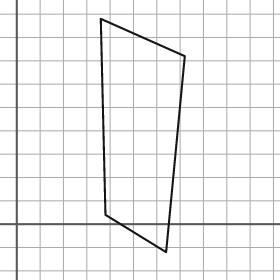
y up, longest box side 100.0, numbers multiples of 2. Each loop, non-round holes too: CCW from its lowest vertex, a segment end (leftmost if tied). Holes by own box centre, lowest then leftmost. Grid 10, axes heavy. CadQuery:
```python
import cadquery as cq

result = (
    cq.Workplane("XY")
    .moveTo(64.0, -12.0)
    .lineTo(72.0, 72.0)
    .lineTo(36.0, 88.0)
    .lineTo(38.0, 4.0)
    .close()
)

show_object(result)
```